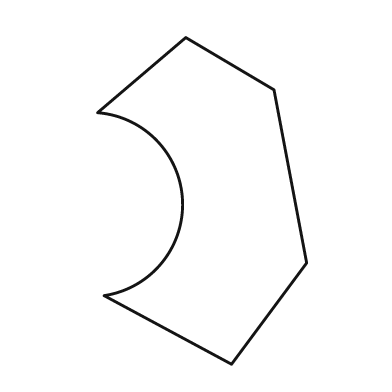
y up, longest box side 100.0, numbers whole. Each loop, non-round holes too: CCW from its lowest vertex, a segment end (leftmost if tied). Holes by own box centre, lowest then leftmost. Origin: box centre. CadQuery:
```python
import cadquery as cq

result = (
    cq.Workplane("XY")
    .moveTo(9.0, -50.0)
    .lineTo(32.0, -19.0)
    .lineTo(22.0, 34.0)
    .lineTo(-5.0, 50.0)
    .lineTo(-32.0, 27.0)
    .threePointArc((-6.0, 0.0), (-30.0, -29.0))
    .close()
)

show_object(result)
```